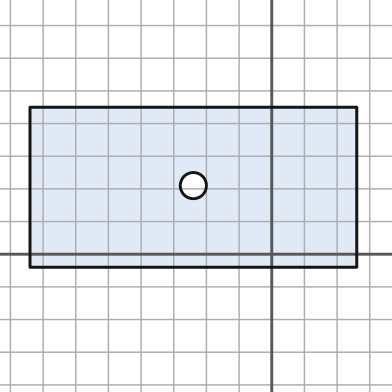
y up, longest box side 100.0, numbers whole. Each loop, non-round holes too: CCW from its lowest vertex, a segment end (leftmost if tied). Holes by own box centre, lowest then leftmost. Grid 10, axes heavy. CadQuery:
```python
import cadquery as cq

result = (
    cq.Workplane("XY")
    .moveTo(-74.0, -4.0)
    .lineTo(26.0, -4.0)
    .lineTo(26.0, 45.0)
    .lineTo(-74.0, 45.0)
    .close()
    .moveTo(-24.0, 21.0)
    .circle(4.0)
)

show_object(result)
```